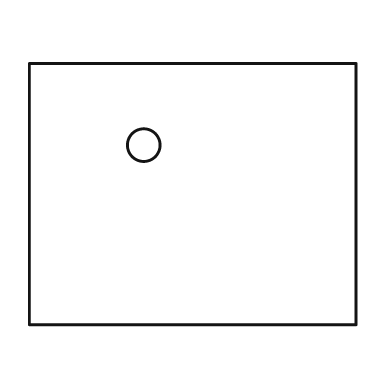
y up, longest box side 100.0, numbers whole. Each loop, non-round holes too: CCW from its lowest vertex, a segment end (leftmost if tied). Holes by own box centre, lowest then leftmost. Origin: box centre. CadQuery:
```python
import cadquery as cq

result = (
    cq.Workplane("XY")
    .moveTo(-50.0, -40.0)
    .lineTo(50.0, -40.0)
    .lineTo(50.0, 40.0)
    .lineTo(-50.0, 40.0)
    .close()
    .moveTo(-15.0, 15.0)
    .circle(5.0)
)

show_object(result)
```